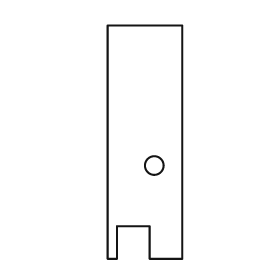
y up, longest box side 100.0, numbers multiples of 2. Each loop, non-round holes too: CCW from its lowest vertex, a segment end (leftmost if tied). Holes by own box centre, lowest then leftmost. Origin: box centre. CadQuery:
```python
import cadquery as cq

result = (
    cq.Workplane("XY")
    .moveTo(-16.0, -50.0)
    .lineTo(-12.0, -50.0)
    .lineTo(-12.0, -36.0)
    .lineTo(2.0, -36.0)
    .lineTo(2.0, -50.0)
    .lineTo(16.0, -50.0)
    .lineTo(16.0, 50.0)
    .lineTo(-16.0, 50.0)
    .close()
    .moveTo(4.0, -10.0)
    .circle(4.0)
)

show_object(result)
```